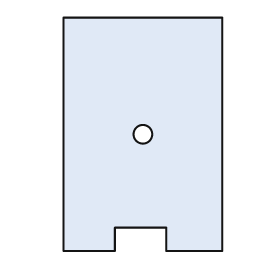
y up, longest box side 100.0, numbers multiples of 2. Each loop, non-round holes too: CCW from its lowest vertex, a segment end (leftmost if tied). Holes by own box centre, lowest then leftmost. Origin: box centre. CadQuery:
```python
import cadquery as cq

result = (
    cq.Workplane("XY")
    .moveTo(-34.0, -50.0)
    .lineTo(-12.0, -50.0)
    .lineTo(-12.0, -40.0)
    .lineTo(10.0, -40.0)
    .lineTo(10.0, -50.0)
    .lineTo(34.0, -50.0)
    .lineTo(34.0, 50.0)
    .lineTo(-34.0, 50.0)
    .close()
    .moveTo(0.0, 0.0)
    .circle(4.0)
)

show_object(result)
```